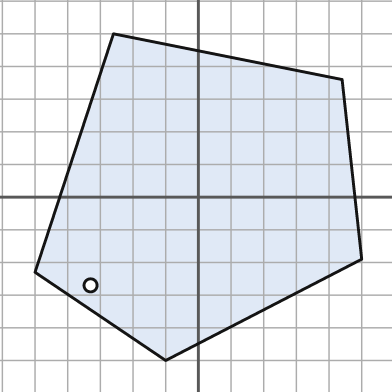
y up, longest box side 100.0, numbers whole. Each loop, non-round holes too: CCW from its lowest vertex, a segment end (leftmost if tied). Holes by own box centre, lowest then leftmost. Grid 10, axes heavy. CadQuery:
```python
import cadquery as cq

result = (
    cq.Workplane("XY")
    .moveTo(-10.0, -50.0)
    .lineTo(50.0, -19.0)
    .lineTo(44.0, 36.0)
    .lineTo(-26.0, 50.0)
    .lineTo(-50.0, -23.0)
    .close()
    .moveTo(-33.0, -27.0)
    .circle(2.0)
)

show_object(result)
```